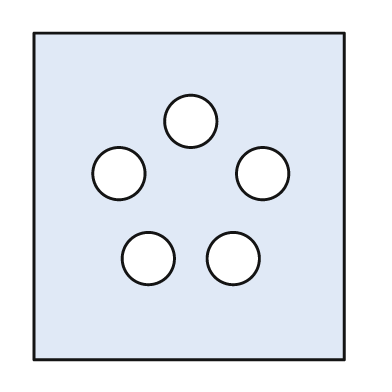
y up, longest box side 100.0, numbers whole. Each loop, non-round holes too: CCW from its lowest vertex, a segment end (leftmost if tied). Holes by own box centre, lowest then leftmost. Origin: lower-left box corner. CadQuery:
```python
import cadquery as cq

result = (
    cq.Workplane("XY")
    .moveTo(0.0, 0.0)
    .lineTo(95.0, 0.0)
    .lineTo(95.0, 100.0)
    .lineTo(0.0, 100.0)
    .close()
    .moveTo(35.0, 31.0)
    .circle(8.0)
    .moveTo(61.0, 31.0)
    .circle(8.0)
    .moveTo(26.0, 57.0)
    .circle(8.0)
    .moveTo(70.0, 57.0)
    .circle(8.0)
    .moveTo(48.0, 73.0)
    .circle(8.0)
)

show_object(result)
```